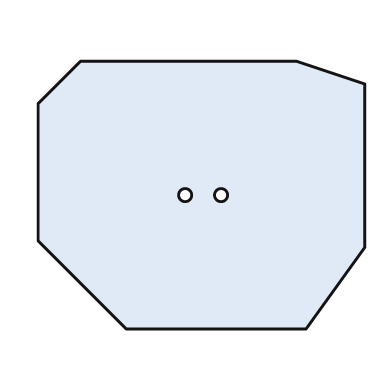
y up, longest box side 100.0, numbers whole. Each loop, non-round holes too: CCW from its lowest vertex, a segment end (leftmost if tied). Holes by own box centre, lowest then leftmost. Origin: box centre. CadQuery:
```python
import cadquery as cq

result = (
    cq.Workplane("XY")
    .moveTo(-23.0, -41.0)
    .lineTo(32.0, -41.0)
    .lineTo(50.0, -16.0)
    .lineTo(50.0, 34.0)
    .lineTo(29.0, 41.0)
    .lineTo(-37.0, 41.0)
    .lineTo(-50.0, 28.0)
    .lineTo(-50.0, -14.0)
    .close()
    .moveTo(-5.0, 0.0)
    .circle(2.0)
    .moveTo(6.0, 0.0)
    .circle(2.0)
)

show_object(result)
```